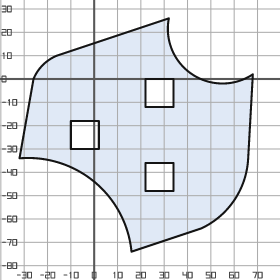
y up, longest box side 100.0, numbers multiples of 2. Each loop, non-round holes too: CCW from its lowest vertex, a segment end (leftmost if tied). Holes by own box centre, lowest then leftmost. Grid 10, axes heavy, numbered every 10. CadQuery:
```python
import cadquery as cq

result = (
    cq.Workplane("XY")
    .moveTo(16.0, -74.0)
    .lineTo(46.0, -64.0)
    .threePointArc((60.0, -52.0), (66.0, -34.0))
    .lineTo(68.0, 2.0)
    .threePointArc((42.0, 2.0), (32.0, 26.0))
    .lineTo(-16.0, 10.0)
    .threePointArc((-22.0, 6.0), (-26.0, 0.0))
    .lineTo(-32.0, -34.0)
    .threePointArc((0.0, -44.0), (16.0, -74.0))
    .close()
    .moveTo(22.0, -48.0)
    .lineTo(34.0, -48.0)
    .lineTo(34.0, -36.0)
    .lineTo(22.0, -36.0)
    .close()
    .moveTo(-10.0, -30.0)
    .lineTo(2.0, -30.0)
    .lineTo(2.0, -18.0)
    .lineTo(-10.0, -18.0)
    .close()
    .moveTo(22.0, -12.0)
    .lineTo(34.0, -12.0)
    .lineTo(34.0, 0.0)
    .lineTo(22.0, 0.0)
    .close()
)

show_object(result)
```